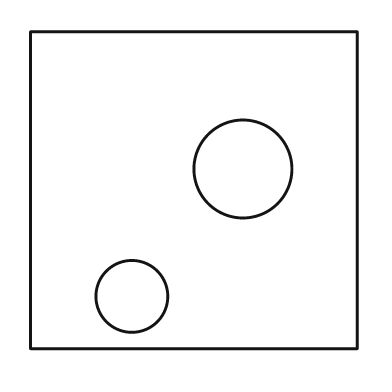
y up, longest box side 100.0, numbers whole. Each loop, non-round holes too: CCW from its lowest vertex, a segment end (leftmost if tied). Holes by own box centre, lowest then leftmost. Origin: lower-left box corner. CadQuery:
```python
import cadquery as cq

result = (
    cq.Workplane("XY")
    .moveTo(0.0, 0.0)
    .lineTo(100.0, 0.0)
    .lineTo(100.0, 97.0)
    .lineTo(0.0, 97.0)
    .close()
    .moveTo(31.0, 16.0)
    .circle(11.0)
    .moveTo(65.0, 55.0)
    .circle(15.0)
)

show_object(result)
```